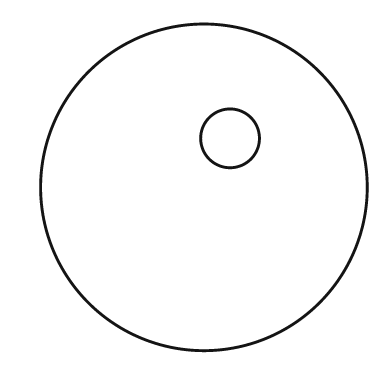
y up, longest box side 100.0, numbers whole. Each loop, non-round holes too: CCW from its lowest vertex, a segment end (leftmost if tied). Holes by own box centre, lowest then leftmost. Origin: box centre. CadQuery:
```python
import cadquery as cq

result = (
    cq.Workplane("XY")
    .moveTo(0.0, 0.0)
    .circle(50.0)
    .moveTo(8.0, 15.0)
    .circle(9.0)
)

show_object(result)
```